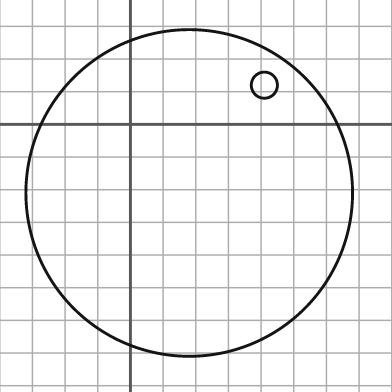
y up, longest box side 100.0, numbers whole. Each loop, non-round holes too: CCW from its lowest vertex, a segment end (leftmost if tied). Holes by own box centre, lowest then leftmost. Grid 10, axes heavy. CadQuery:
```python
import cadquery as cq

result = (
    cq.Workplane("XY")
    .moveTo(18.0, -21.0)
    .circle(50.0)
    .moveTo(41.0, 12.0)
    .circle(4.0)
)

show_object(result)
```